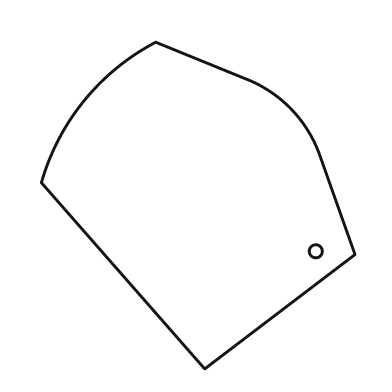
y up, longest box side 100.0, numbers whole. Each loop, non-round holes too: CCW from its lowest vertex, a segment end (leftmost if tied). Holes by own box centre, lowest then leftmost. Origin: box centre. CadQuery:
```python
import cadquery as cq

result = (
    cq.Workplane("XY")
    .moveTo(2.0, -50.0)
    .lineTo(48.0, -15.0)
    .lineTo(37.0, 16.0)
    .threePointArc((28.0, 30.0), (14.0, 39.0))
    .lineTo(-13.0, 50.0)
    .threePointArc((-35.0, 32.0), (-48.0, 7.0))
    .close()
    .moveTo(36.0, -14.0)
    .circle(2.0)
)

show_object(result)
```